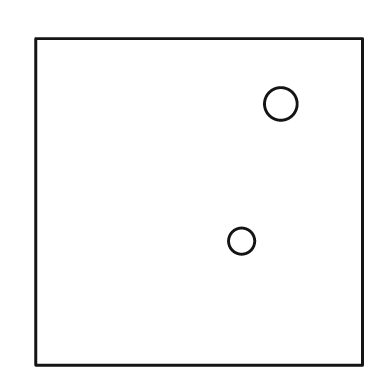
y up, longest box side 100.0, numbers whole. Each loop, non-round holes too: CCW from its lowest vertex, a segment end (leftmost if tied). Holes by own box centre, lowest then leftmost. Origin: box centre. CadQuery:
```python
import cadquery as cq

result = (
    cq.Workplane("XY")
    .moveTo(-50.0, -50.0)
    .lineTo(50.0, -50.0)
    .lineTo(50.0, 50.0)
    .lineTo(-50.0, 50.0)
    .close()
    .moveTo(13.0, -12.0)
    .circle(4.0)
    .moveTo(25.0, 30.0)
    .circle(5.0)
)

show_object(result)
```